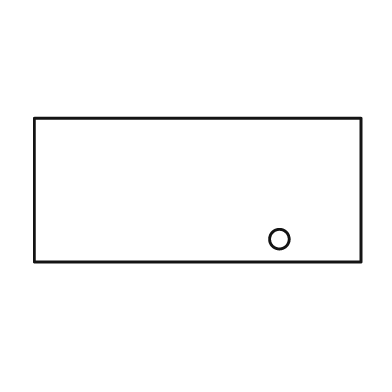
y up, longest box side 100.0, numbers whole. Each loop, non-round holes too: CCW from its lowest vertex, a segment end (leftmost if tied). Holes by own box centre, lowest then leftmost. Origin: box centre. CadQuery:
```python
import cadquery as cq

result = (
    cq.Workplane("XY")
    .moveTo(-50.0, -22.0)
    .lineTo(50.0, -22.0)
    .lineTo(50.0, 22.0)
    .lineTo(-50.0, 22.0)
    .close()
    .moveTo(25.0, -15.0)
    .circle(3.0)
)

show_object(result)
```